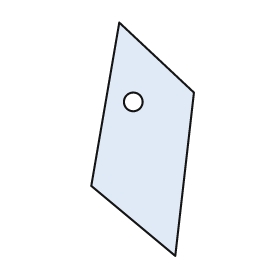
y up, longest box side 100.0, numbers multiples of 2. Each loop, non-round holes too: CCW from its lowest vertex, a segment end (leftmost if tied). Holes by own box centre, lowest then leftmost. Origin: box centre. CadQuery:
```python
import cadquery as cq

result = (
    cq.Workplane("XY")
    .moveTo(14.0, -50.0)
    .lineTo(22.0, 20.0)
    .lineTo(-10.0, 50.0)
    .lineTo(-22.0, -20.0)
    .close()
    .moveTo(-4.0, 16.0)
    .circle(4.0)
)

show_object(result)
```